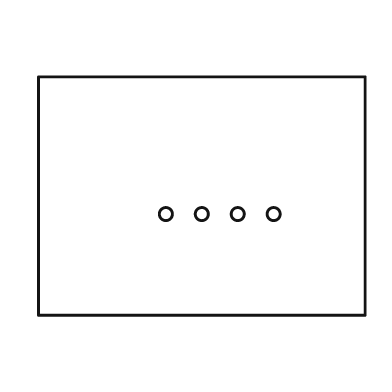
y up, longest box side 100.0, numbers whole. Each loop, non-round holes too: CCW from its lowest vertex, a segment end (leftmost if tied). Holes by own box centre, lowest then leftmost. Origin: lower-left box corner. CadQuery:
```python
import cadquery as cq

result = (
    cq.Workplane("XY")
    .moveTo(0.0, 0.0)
    .lineTo(100.0, 0.0)
    .lineTo(100.0, 73.0)
    .lineTo(0.0, 73.0)
    .close()
    .moveTo(39.0, 31.0)
    .circle(2.0)
    .moveTo(50.0, 31.0)
    .circle(2.0)
    .moveTo(61.0, 31.0)
    .circle(2.0)
    .moveTo(72.0, 31.0)
    .circle(2.0)
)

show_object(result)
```